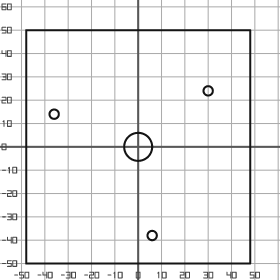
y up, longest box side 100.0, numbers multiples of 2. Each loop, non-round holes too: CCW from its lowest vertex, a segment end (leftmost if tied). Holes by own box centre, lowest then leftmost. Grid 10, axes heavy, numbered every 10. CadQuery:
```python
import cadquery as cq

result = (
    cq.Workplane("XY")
    .moveTo(-48.0, -50.0)
    .lineTo(48.0, -50.0)
    .lineTo(48.0, 50.0)
    .lineTo(-48.0, 50.0)
    .close()
    .moveTo(6.0, -38.0)
    .circle(2.0)
    .moveTo(0.0, 0.0)
    .circle(6.0)
    .moveTo(-36.0, 14.0)
    .circle(2.0)
    .moveTo(30.0, 24.0)
    .circle(2.0)
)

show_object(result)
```